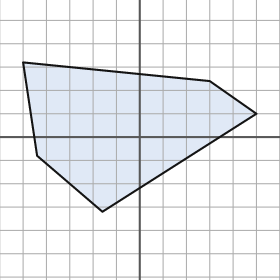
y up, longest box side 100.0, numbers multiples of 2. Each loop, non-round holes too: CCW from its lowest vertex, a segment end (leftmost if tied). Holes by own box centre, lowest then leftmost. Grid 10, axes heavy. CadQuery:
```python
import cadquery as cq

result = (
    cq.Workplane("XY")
    .moveTo(-16.0, -32.0)
    .lineTo(50.0, 10.0)
    .lineTo(30.0, 24.0)
    .lineTo(-50.0, 32.0)
    .lineTo(-44.0, -8.0)
    .close()
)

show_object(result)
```